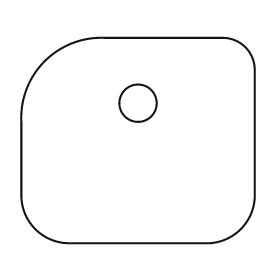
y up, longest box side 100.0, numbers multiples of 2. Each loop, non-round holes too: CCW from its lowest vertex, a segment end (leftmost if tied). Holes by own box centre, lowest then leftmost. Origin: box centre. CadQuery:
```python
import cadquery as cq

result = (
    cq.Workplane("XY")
    .moveTo(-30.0, -44.0)
    .lineTo(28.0, -44.0)
    .threePointArc((44.0, -38.0), (50.0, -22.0))
    .lineTo(50.0, 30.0)
    .threePointArc((46.0, 40.0), (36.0, 44.0))
    .lineTo(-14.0, 44.0)
    .threePointArc((-40.0, 34.0), (-50.0, 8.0))
    .lineTo(-50.0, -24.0)
    .threePointArc((-44.0, -38.0), (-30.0, -44.0))
    .close()
    .moveTo(0.0, 16.0)
    .circle(8.0)
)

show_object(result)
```